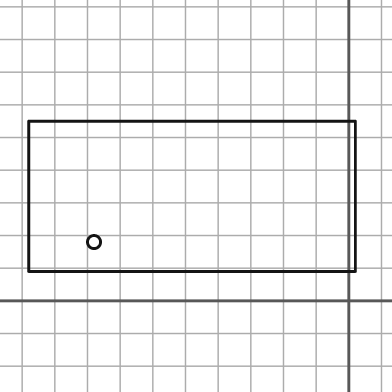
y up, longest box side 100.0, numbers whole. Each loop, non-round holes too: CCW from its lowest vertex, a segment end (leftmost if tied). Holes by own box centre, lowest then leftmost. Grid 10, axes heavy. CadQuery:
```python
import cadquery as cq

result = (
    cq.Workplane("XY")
    .moveTo(-98.0, 9.0)
    .lineTo(2.0, 9.0)
    .lineTo(2.0, 55.0)
    .lineTo(-98.0, 55.0)
    .close()
    .moveTo(-78.0, 18.0)
    .circle(2.0)
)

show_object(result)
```